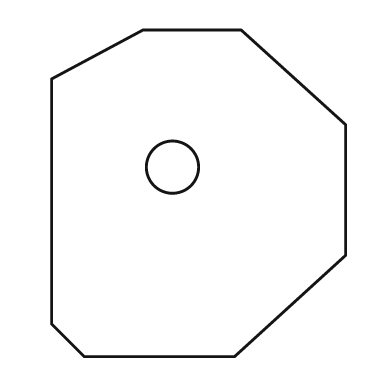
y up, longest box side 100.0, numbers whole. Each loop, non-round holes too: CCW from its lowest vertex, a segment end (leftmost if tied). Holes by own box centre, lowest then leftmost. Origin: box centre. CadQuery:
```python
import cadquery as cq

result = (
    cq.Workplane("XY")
    .moveTo(-35.0, -50.0)
    .lineTo(11.0, -50.0)
    .lineTo(45.0, -19.0)
    .lineTo(45.0, 21.0)
    .lineTo(13.0, 50.0)
    .lineTo(-17.0, 50.0)
    .lineTo(-45.0, 35.0)
    .lineTo(-45.0, -40.0)
    .close()
    .moveTo(-8.0, 8.0)
    .circle(8.0)
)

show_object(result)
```